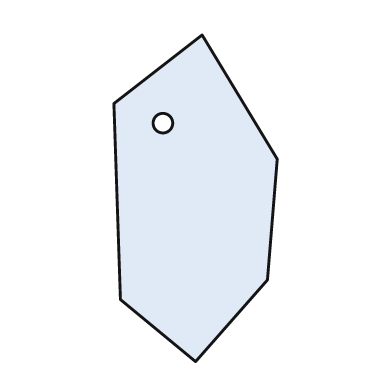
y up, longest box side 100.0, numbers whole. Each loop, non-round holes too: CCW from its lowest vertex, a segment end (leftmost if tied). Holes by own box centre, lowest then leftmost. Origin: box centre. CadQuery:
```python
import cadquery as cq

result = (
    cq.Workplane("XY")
    .moveTo(0.0, -50.0)
    .lineTo(22.0, -25.0)
    .lineTo(25.0, 12.0)
    .lineTo(2.0, 50.0)
    .lineTo(-25.0, 29.0)
    .lineTo(-23.0, -31.0)
    .close()
    .moveTo(-10.0, 23.0)
    .circle(3.0)
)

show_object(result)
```